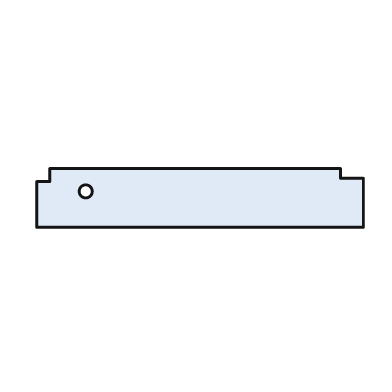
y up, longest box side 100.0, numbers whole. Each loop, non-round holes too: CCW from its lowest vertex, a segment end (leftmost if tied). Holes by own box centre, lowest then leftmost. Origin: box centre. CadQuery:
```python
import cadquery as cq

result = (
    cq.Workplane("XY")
    .moveTo(-50.0, -9.0)
    .lineTo(50.0, -9.0)
    .lineTo(50.0, 6.0)
    .lineTo(43.0, 6.0)
    .lineTo(43.0, 9.0)
    .lineTo(-46.0, 9.0)
    .lineTo(-46.0, 5.0)
    .lineTo(-50.0, 5.0)
    .close()
    .moveTo(-35.0, 2.0)
    .circle(2.0)
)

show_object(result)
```